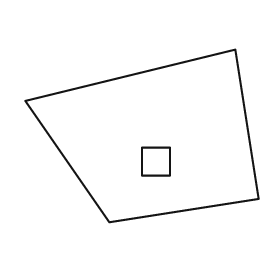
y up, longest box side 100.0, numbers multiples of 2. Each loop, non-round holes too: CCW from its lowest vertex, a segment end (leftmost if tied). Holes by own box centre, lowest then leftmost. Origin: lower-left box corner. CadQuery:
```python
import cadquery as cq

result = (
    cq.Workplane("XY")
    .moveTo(36.0, 0.0)
    .lineTo(100.0, 10.0)
    .lineTo(90.0, 74.0)
    .lineTo(0.0, 52.0)
    .close()
    .moveTo(50.0, 20.0)
    .lineTo(62.0, 20.0)
    .lineTo(62.0, 32.0)
    .lineTo(50.0, 32.0)
    .close()
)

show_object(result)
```